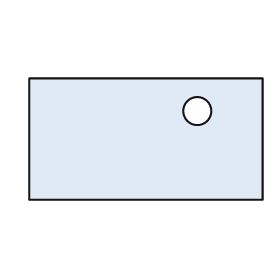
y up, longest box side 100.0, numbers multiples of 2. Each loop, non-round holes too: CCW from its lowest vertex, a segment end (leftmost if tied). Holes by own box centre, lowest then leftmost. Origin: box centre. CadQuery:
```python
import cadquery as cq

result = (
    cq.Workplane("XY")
    .moveTo(-50.0, -26.0)
    .lineTo(50.0, -26.0)
    .lineTo(50.0, 26.0)
    .lineTo(-50.0, 26.0)
    .close()
    .moveTo(22.0, 12.0)
    .circle(6.0)
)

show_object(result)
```